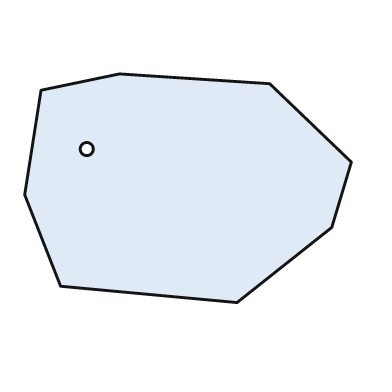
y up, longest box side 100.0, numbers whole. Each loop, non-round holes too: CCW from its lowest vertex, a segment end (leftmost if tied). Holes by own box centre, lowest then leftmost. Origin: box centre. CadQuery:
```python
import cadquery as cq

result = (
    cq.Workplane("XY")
    .moveTo(15.0, -35.0)
    .lineTo(44.0, -12.0)
    .lineTo(50.0, 8.0)
    .lineTo(25.0, 32.0)
    .lineTo(-21.0, 35.0)
    .lineTo(-45.0, 30.0)
    .lineTo(-50.0, -2.0)
    .lineTo(-39.0, -30.0)
    .close()
    .moveTo(-31.0, 12.0)
    .circle(2.0)
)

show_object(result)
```